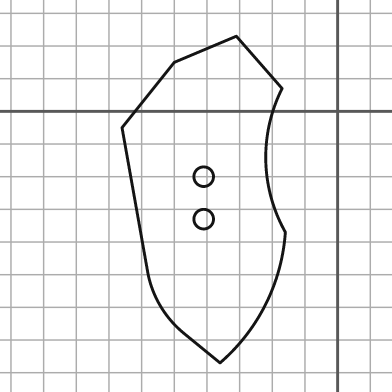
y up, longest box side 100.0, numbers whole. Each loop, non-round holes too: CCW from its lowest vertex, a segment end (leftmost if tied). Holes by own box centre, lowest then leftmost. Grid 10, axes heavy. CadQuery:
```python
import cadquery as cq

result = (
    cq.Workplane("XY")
    .moveTo(-36.0, -77.0)
    .threePointArc((-22.0, -59.0), (-16.0, -37.0))
    .threePointArc((-22.0, -15.0), (-17.0, 7.0))
    .lineTo(-31.0, 23.0)
    .lineTo(-50.0, 15.0)
    .lineTo(-66.0, -5.0)
    .lineTo(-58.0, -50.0)
    .threePointArc((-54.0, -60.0), (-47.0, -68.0))
    .close()
    .moveTo(-41.0, -33.0)
    .circle(3.0)
    .moveTo(-41.0, -20.0)
    .circle(3.0)
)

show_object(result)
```